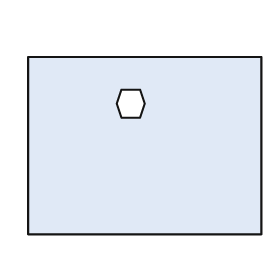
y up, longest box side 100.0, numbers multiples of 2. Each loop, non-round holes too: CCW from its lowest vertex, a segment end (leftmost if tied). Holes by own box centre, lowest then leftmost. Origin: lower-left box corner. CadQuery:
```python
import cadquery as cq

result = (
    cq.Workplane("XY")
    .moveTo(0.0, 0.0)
    .lineTo(100.0, 0.0)
    .lineTo(100.0, 76.0)
    .lineTo(0.0, 76.0)
    .close()
    .moveTo(40.0, 50.0)
    .lineTo(48.0, 50.0)
    .lineTo(50.0, 56.0)
    .lineTo(48.0, 62.0)
    .lineTo(40.0, 62.0)
    .lineTo(38.0, 56.0)
    .close()
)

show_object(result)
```